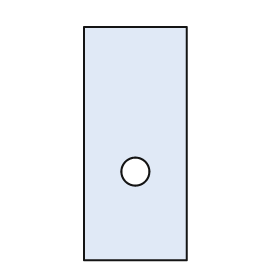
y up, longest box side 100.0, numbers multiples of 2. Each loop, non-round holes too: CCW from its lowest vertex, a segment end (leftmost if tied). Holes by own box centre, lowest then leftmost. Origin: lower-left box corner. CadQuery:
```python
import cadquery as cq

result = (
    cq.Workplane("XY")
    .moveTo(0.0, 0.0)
    .lineTo(44.0, 0.0)
    .lineTo(44.0, 100.0)
    .lineTo(0.0, 100.0)
    .close()
    .moveTo(22.0, 38.0)
    .circle(6.0)
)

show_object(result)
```